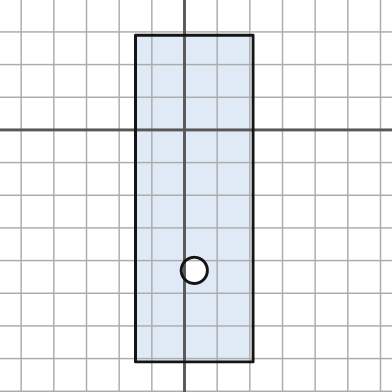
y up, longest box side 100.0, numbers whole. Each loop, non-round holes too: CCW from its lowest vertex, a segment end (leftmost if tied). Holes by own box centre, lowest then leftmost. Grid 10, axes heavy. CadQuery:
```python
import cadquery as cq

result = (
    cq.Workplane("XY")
    .moveTo(-15.0, -71.0)
    .lineTo(21.0, -71.0)
    .lineTo(21.0, 29.0)
    .lineTo(-15.0, 29.0)
    .close()
    .moveTo(3.0, -43.0)
    .circle(4.0)
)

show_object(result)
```